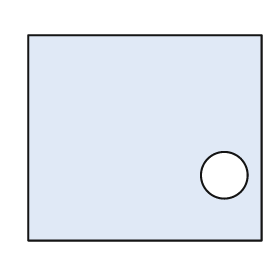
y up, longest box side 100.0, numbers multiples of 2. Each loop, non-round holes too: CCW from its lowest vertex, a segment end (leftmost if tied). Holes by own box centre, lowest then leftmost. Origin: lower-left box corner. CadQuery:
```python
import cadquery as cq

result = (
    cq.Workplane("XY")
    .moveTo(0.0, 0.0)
    .lineTo(100.0, 0.0)
    .lineTo(100.0, 88.0)
    .lineTo(0.0, 88.0)
    .close()
    .moveTo(84.0, 28.0)
    .circle(10.0)
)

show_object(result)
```